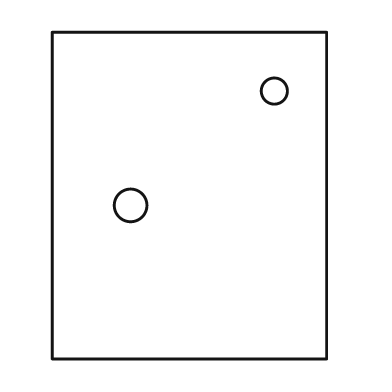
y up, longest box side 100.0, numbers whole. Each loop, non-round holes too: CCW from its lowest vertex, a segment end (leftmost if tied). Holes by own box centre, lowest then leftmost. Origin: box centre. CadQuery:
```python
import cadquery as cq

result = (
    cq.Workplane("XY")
    .moveTo(-42.0, -50.0)
    .lineTo(42.0, -50.0)
    .lineTo(42.0, 50.0)
    .lineTo(-42.0, 50.0)
    .close()
    .moveTo(-18.0, -3.0)
    .circle(5.0)
    .moveTo(26.0, 32.0)
    .circle(4.0)
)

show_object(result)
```